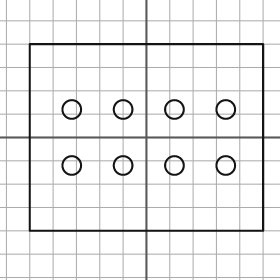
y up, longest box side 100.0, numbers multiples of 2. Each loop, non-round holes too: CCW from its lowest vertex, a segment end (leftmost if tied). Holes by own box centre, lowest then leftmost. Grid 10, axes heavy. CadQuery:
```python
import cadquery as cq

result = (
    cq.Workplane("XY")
    .moveTo(-50.0, -40.0)
    .lineTo(50.0, -40.0)
    .lineTo(50.0, 40.0)
    .lineTo(-50.0, 40.0)
    .close()
    .moveTo(-32.0, -12.0)
    .circle(4.0)
    .moveTo(-10.0, -12.0)
    .circle(4.0)
    .moveTo(12.0, -12.0)
    .circle(4.0)
    .moveTo(34.0, -12.0)
    .circle(4.0)
    .moveTo(-32.0, 12.0)
    .circle(4.0)
    .moveTo(-10.0, 12.0)
    .circle(4.0)
    .moveTo(12.0, 12.0)
    .circle(4.0)
    .moveTo(34.0, 12.0)
    .circle(4.0)
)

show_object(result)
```